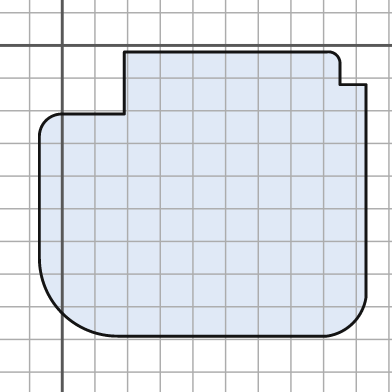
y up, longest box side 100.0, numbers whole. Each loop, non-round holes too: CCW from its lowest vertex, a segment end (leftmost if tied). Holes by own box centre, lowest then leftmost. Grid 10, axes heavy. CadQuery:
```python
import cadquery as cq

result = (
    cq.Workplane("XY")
    .moveTo(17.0, -89.0)
    .lineTo(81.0, -89.0)
    .threePointArc((89.0, -85.0), (93.0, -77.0))
    .lineTo(93.0, -12.0)
    .lineTo(85.0, -12.0)
    .lineTo(85.0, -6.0)
    .threePointArc((84.0, -3.0), (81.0, -2.0))
    .lineTo(19.0, -2.0)
    .lineTo(19.0, -21.0)
    .lineTo(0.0, -21.0)
    .threePointArc((-5.0, -23.0), (-7.0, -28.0))
    .lineTo(-7.0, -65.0)
    .threePointArc((0.0, -82.0), (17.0, -89.0))
    .close()
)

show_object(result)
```